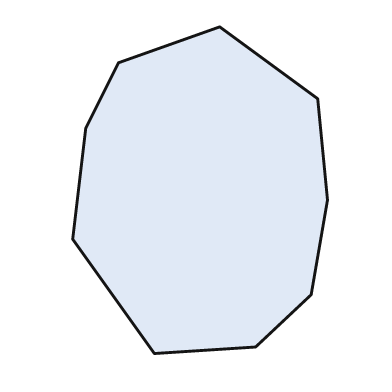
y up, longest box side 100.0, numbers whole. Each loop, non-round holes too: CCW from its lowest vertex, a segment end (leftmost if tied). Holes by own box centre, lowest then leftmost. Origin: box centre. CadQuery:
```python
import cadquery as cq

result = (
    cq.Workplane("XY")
    .moveTo(-14.0, -50.0)
    .lineTo(17.0, -48.0)
    .lineTo(34.0, -32.0)
    .lineTo(39.0, -3.0)
    .lineTo(36.0, 28.0)
    .lineTo(6.0, 50.0)
    .lineTo(-25.0, 39.0)
    .lineTo(-35.0, 19.0)
    .lineTo(-39.0, -15.0)
    .close()
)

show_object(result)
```